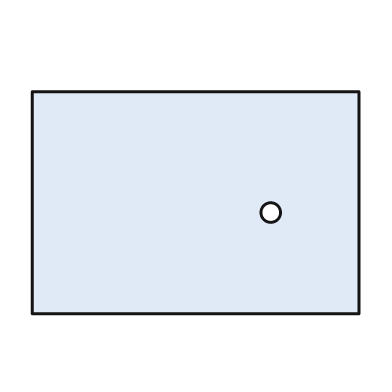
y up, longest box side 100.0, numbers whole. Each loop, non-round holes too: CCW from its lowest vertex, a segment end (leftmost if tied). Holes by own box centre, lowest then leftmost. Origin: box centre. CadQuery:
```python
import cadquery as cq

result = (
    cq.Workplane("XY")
    .moveTo(-50.0, -34.0)
    .lineTo(50.0, -34.0)
    .lineTo(50.0, 34.0)
    .lineTo(-50.0, 34.0)
    .close()
    .moveTo(23.0, -3.0)
    .circle(3.0)
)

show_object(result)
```